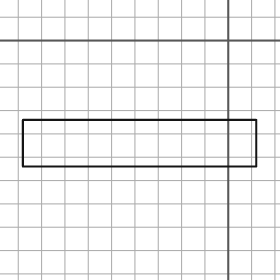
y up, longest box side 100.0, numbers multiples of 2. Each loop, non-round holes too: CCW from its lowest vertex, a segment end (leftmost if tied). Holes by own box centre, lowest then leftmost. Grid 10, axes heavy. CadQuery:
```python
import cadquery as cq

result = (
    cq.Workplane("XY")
    .moveTo(-88.0, -54.0)
    .lineTo(12.0, -54.0)
    .lineTo(12.0, -34.0)
    .lineTo(-88.0, -34.0)
    .close()
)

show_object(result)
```